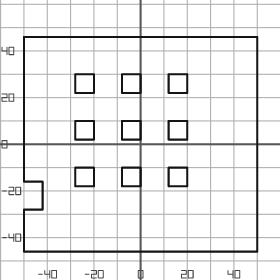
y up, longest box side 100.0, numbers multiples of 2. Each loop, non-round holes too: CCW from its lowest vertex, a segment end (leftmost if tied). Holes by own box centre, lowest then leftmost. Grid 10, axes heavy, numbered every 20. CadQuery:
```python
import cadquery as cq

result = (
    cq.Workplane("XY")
    .moveTo(-50.0, -46.0)
    .lineTo(50.0, -46.0)
    .lineTo(50.0, 46.0)
    .lineTo(-50.0, 46.0)
    .lineTo(-50.0, -16.0)
    .lineTo(-42.0, -16.0)
    .lineTo(-42.0, -28.0)
    .lineTo(-50.0, -28.0)
    .close()
    .moveTo(-28.0, -18.0)
    .lineTo(-20.0, -18.0)
    .lineTo(-20.0, -10.0)
    .lineTo(-28.0, -10.0)
    .close()
    .moveTo(-8.0, -18.0)
    .lineTo(0.0, -18.0)
    .lineTo(0.0, -10.0)
    .lineTo(-8.0, -10.0)
    .close()
    .moveTo(12.0, -18.0)
    .lineTo(20.0, -18.0)
    .lineTo(20.0, -10.0)
    .lineTo(12.0, -10.0)
    .close()
    .moveTo(-28.0, 2.0)
    .lineTo(-20.0, 2.0)
    .lineTo(-20.0, 10.0)
    .lineTo(-28.0, 10.0)
    .close()
    .moveTo(-8.0, 2.0)
    .lineTo(0.0, 2.0)
    .lineTo(0.0, 10.0)
    .lineTo(-8.0, 10.0)
    .close()
    .moveTo(12.0, 2.0)
    .lineTo(20.0, 2.0)
    .lineTo(20.0, 10.0)
    .lineTo(12.0, 10.0)
    .close()
    .moveTo(-28.0, 22.0)
    .lineTo(-20.0, 22.0)
    .lineTo(-20.0, 30.0)
    .lineTo(-28.0, 30.0)
    .close()
    .moveTo(-8.0, 22.0)
    .lineTo(0.0, 22.0)
    .lineTo(0.0, 30.0)
    .lineTo(-8.0, 30.0)
    .close()
    .moveTo(12.0, 22.0)
    .lineTo(20.0, 22.0)
    .lineTo(20.0, 30.0)
    .lineTo(12.0, 30.0)
    .close()
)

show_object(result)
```